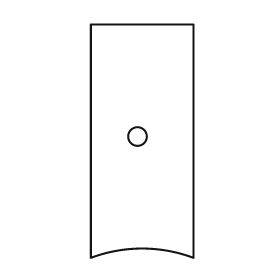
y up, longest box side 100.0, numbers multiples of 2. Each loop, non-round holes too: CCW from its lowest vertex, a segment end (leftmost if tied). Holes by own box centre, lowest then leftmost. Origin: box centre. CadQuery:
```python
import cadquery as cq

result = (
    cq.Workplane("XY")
    .moveTo(-22.0, -50.0)
    .threePointArc((0.0, -46.0), (22.0, -50.0))
    .lineTo(22.0, 50.0)
    .lineTo(-22.0, 50.0)
    .close()
    .moveTo(-2.0, 2.0)
    .circle(4.0)
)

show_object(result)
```